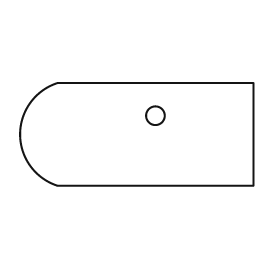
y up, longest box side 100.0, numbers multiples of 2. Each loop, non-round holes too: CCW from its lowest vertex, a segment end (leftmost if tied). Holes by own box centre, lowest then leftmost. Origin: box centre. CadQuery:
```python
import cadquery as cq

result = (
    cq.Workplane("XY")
    .moveTo(-34.0, -22.0)
    .lineTo(50.0, -22.0)
    .lineTo(50.0, 22.0)
    .lineTo(-34.0, 22.0)
    .threePointArc((-50.0, 0.0), (-34.0, -22.0))
    .close()
    .moveTo(8.0, 8.0)
    .circle(4.0)
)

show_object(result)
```